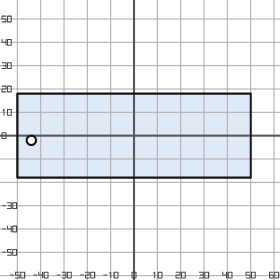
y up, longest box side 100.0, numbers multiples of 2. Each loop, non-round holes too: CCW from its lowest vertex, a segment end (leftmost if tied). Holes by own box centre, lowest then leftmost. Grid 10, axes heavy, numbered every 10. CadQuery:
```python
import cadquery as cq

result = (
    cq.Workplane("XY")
    .moveTo(-50.0, -18.0)
    .lineTo(50.0, -18.0)
    .lineTo(50.0, 18.0)
    .lineTo(-50.0, 18.0)
    .close()
    .moveTo(-44.0, -2.0)
    .circle(2.0)
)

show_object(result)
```